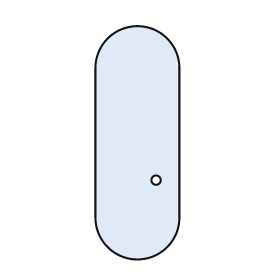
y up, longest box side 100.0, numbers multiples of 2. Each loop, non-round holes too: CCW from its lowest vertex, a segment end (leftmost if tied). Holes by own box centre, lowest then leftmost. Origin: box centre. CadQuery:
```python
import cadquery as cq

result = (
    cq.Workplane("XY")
    .moveTo(-18.0, -32.0)
    .threePointArc((0.0, -50.0), (18.0, -32.0))
    .lineTo(18.0, 32.0)
    .threePointArc((0.0, 50.0), (-18.0, 32.0))
    .close()
    .moveTo(8.0, -16.0)
    .circle(2.0)
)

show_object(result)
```